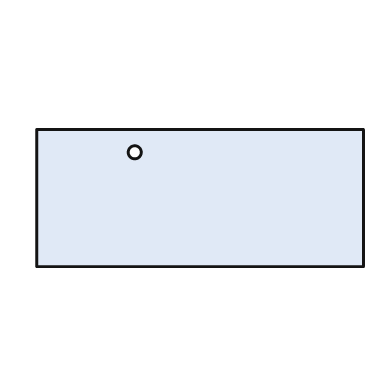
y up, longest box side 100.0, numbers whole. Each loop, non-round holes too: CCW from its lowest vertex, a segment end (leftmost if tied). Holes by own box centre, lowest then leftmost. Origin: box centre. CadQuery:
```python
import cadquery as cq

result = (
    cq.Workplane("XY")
    .moveTo(-50.0, -21.0)
    .lineTo(50.0, -21.0)
    .lineTo(50.0, 21.0)
    .lineTo(-50.0, 21.0)
    .close()
    .moveTo(-20.0, 14.0)
    .circle(2.0)
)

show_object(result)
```